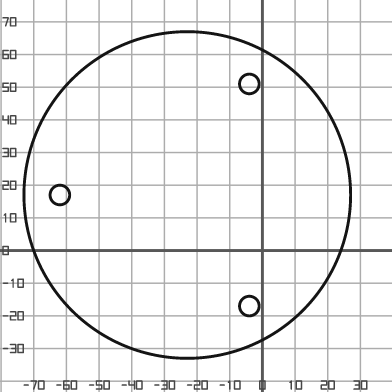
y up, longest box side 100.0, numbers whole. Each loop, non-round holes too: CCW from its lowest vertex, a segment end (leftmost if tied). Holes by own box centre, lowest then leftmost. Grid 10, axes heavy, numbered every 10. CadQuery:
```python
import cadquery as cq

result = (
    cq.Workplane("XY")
    .moveTo(-23.0, 17.0)
    .circle(50.0)
    .moveTo(-4.0, -17.0)
    .circle(3.0)
    .moveTo(-62.0, 17.0)
    .circle(3.0)
    .moveTo(-4.0, 51.0)
    .circle(3.0)
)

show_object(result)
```